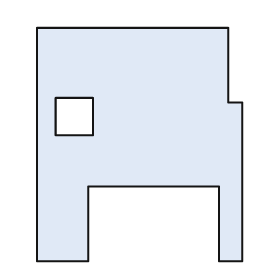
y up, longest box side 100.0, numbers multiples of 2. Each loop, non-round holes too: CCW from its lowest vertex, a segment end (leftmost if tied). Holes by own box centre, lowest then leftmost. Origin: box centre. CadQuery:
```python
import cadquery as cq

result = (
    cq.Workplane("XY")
    .moveTo(-44.0, -50.0)
    .lineTo(-22.0, -50.0)
    .lineTo(-22.0, -18.0)
    .lineTo(34.0, -18.0)
    .lineTo(34.0, -50.0)
    .lineTo(44.0, -50.0)
    .lineTo(44.0, 18.0)
    .lineTo(38.0, 18.0)
    .lineTo(38.0, 50.0)
    .lineTo(-44.0, 50.0)
    .close()
    .moveTo(-36.0, 4.0)
    .lineTo(-20.0, 4.0)
    .lineTo(-20.0, 20.0)
    .lineTo(-36.0, 20.0)
    .close()
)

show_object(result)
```